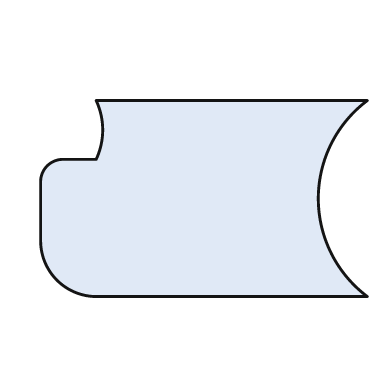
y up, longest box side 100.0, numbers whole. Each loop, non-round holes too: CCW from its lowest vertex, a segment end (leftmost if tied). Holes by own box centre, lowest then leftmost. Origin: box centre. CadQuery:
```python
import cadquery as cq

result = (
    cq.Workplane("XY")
    .moveTo(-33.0, -30.0)
    .lineTo(50.0, -30.0)
    .threePointArc((35.0, 0.0), (50.0, 30.0))
    .lineTo(-33.0, 30.0)
    .threePointArc((-31.0, 21.0), (-33.0, 12.0))
    .lineTo(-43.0, 12.0)
    .threePointArc((-48.0, 10.0), (-50.0, 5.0))
    .lineTo(-50.0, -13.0)
    .threePointArc((-45.0, -25.0), (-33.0, -30.0))
    .close()
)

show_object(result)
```